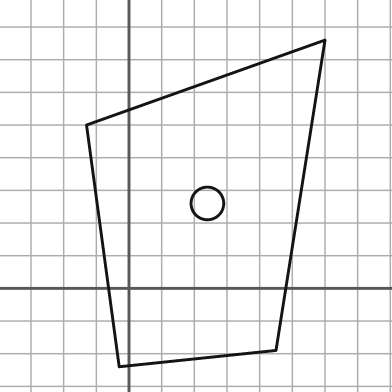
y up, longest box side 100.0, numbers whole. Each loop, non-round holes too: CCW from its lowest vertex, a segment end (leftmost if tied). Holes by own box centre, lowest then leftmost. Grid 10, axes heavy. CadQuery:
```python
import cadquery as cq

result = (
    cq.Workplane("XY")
    .moveTo(-3.0, -24.0)
    .lineTo(45.0, -19.0)
    .lineTo(60.0, 76.0)
    .lineTo(-13.0, 50.0)
    .close()
    .moveTo(24.0, 26.0)
    .circle(5.0)
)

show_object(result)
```